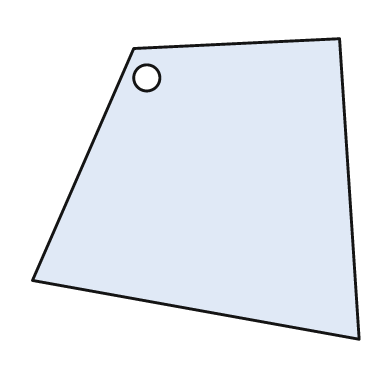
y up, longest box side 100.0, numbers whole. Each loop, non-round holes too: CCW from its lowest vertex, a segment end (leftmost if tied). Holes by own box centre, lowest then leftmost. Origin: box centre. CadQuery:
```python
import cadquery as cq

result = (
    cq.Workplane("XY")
    .moveTo(50.0, -46.0)
    .lineTo(44.0, 46.0)
    .lineTo(-19.0, 43.0)
    .lineTo(-50.0, -28.0)
    .close()
    .moveTo(-15.0, 34.0)
    .circle(4.0)
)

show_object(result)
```